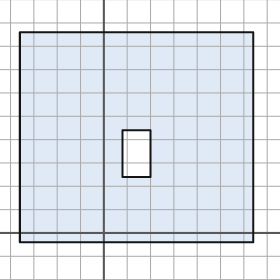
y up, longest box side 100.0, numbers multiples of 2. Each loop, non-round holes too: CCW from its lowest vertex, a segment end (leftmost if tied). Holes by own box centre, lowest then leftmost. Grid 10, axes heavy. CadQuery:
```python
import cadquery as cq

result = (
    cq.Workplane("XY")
    .moveTo(-36.0, -4.0)
    .lineTo(64.0, -4.0)
    .lineTo(64.0, 86.0)
    .lineTo(-36.0, 86.0)
    .close()
    .moveTo(8.0, 24.0)
    .lineTo(20.0, 24.0)
    .lineTo(20.0, 44.0)
    .lineTo(8.0, 44.0)
    .close()
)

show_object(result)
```